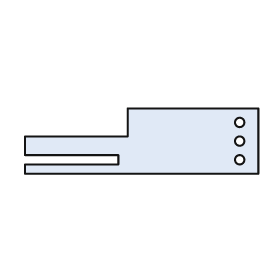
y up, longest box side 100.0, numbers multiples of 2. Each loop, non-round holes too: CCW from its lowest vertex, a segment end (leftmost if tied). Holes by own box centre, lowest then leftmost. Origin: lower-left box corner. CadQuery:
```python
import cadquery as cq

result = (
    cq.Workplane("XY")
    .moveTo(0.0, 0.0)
    .lineTo(100.0, 0.0)
    .lineTo(100.0, 28.0)
    .lineTo(44.0, 28.0)
    .lineTo(44.0, 16.0)
    .lineTo(0.0, 16.0)
    .lineTo(0.0, 8.0)
    .lineTo(40.0, 8.0)
    .lineTo(40.0, 4.0)
    .lineTo(0.0, 4.0)
    .close()
    .moveTo(92.0, 6.0)
    .circle(2.0)
    .moveTo(92.0, 14.0)
    .circle(2.0)
    .moveTo(92.0, 22.0)
    .circle(2.0)
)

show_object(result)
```